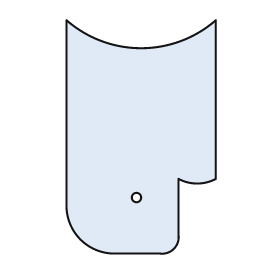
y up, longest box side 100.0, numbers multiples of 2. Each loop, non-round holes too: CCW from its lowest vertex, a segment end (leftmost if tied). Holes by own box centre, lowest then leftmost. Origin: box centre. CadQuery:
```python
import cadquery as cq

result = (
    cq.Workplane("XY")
    .moveTo(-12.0, -50.0)
    .lineTo(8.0, -50.0)
    .threePointArc((14.0, -48.0), (16.0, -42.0))
    .lineTo(16.0, -18.0)
    .threePointArc((24.0, -20.0), (32.0, -18.0))
    .lineTo(32.0, 50.0)
    .threePointArc((0.0, 38.0), (-32.0, 50.0))
    .lineTo(-32.0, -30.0)
    .threePointArc((-26.0, -44.0), (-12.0, -50.0))
    .close()
    .moveTo(-2.0, -26.0)
    .circle(2.0)
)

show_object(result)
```